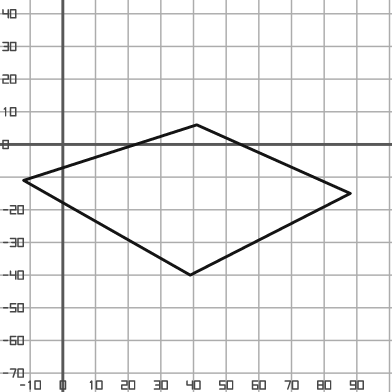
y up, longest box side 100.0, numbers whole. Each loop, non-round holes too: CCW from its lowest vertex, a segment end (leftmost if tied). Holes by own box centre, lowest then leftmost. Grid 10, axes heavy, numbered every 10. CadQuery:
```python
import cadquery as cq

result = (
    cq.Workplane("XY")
    .moveTo(39.0, -40.0)
    .lineTo(88.0, -15.0)
    .lineTo(41.0, 6.0)
    .lineTo(-12.0, -11.0)
    .close()
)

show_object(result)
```